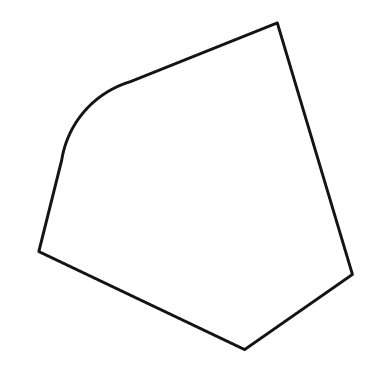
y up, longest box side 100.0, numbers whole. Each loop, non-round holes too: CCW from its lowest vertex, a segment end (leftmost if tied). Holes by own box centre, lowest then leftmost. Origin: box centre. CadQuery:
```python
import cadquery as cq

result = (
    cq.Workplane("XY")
    .moveTo(15.0, -50.0)
    .lineTo(48.0, -27.0)
    .lineTo(25.0, 50.0)
    .lineTo(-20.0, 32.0)
    .threePointArc((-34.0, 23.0), (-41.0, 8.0))
    .lineTo(-48.0, -20.0)
    .close()
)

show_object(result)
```